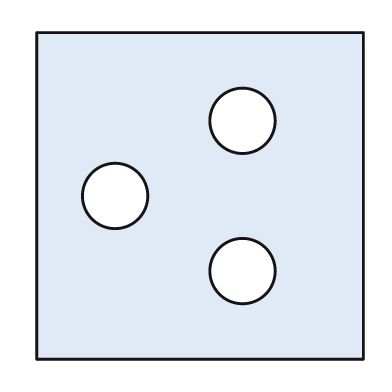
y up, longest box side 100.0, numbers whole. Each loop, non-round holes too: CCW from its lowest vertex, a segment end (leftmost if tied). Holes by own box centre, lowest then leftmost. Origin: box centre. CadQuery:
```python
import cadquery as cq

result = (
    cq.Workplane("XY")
    .moveTo(-50.0, -50.0)
    .lineTo(50.0, -50.0)
    .lineTo(50.0, 50.0)
    .lineTo(-50.0, 50.0)
    .close()
    .moveTo(13.0, -23.0)
    .circle(10.0)
    .moveTo(-26.0, 0.0)
    .circle(10.0)
    .moveTo(13.0, 23.0)
    .circle(10.0)
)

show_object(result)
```